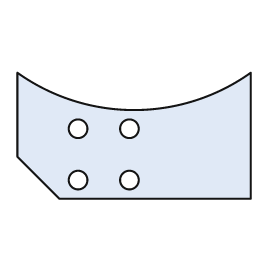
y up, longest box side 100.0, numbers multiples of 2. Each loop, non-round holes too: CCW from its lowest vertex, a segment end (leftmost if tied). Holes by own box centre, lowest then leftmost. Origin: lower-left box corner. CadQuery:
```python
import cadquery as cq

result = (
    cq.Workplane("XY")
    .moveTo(18.0, 0.0)
    .lineTo(100.0, 0.0)
    .lineTo(100.0, 54.0)
    .threePointArc((50.0, 38.0), (0.0, 54.0))
    .lineTo(0.0, 18.0)
    .close()
    .moveTo(26.0, 8.0)
    .circle(4.0)
    .moveTo(48.0, 8.0)
    .circle(4.0)
    .moveTo(26.0, 30.0)
    .circle(4.0)
    .moveTo(48.0, 30.0)
    .circle(4.0)
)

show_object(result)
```